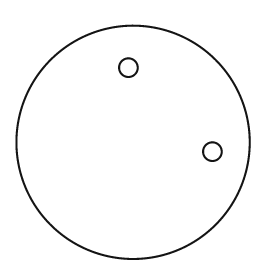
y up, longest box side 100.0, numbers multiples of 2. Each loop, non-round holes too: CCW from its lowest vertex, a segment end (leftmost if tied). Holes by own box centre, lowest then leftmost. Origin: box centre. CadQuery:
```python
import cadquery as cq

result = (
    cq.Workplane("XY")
    .moveTo(0.0, 0.0)
    .circle(50.0)
    .moveTo(34.0, -4.0)
    .circle(4.0)
    .moveTo(-2.0, 32.0)
    .circle(4.0)
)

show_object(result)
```